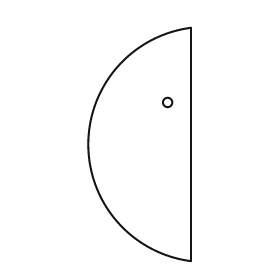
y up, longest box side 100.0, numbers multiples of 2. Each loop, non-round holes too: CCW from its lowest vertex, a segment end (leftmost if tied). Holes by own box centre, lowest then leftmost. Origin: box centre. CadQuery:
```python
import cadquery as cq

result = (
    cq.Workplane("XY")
    .moveTo(22.0, -50.0)
    .lineTo(22.0, 50.0)
    .threePointArc((-22.0, 0.0), (22.0, -50.0))
    .close()
    .moveTo(12.0, 18.0)
    .circle(2.0)
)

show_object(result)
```